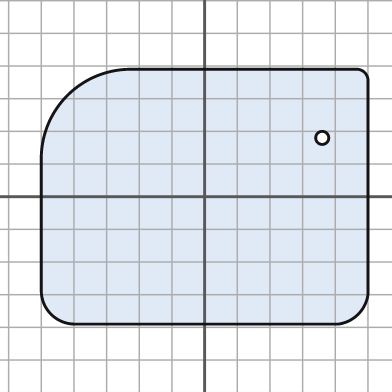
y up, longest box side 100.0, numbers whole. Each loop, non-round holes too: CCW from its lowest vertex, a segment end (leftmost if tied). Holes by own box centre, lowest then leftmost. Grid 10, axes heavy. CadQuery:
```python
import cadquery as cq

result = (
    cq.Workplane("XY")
    .moveTo(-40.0, -39.0)
    .lineTo(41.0, -39.0)
    .threePointArc((47.0, -36.0), (50.0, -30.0))
    .lineTo(50.0, 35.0)
    .threePointArc((49.0, 38.0), (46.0, 39.0))
    .lineTo(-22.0, 39.0)
    .threePointArc((-42.0, 31.0), (-50.0, 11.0))
    .lineTo(-50.0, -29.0)
    .threePointArc((-47.0, -36.0), (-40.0, -39.0))
    .close()
    .moveTo(36.0, 18.0)
    .circle(2.0)
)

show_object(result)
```